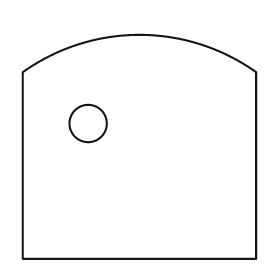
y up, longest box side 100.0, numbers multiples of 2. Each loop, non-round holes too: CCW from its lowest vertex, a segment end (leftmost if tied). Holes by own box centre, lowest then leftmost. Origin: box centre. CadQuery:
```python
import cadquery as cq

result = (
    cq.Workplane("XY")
    .moveTo(-50.0, -48.0)
    .lineTo(50.0, -48.0)
    .lineTo(50.0, 32.0)
    .threePointArc((0.0, 48.0), (-50.0, 32.0))
    .close()
    .moveTo(-22.0, 10.0)
    .circle(8.0)
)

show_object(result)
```